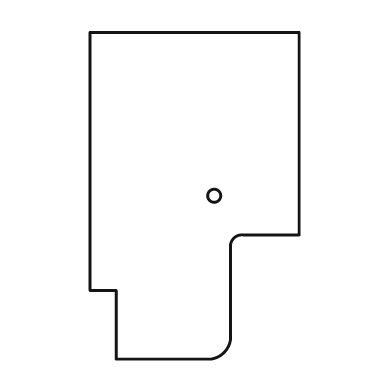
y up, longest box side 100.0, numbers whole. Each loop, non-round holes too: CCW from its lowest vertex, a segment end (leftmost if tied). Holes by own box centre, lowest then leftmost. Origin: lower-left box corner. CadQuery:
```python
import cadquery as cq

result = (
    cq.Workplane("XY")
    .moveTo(8.0, 0.0)
    .lineTo(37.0, 0.0)
    .threePointArc((41.0, 2.0), (43.0, 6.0))
    .lineTo(43.0, 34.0)
    .threePointArc((44.0, 37.0), (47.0, 38.0))
    .lineTo(64.0, 38.0)
    .lineTo(64.0, 100.0)
    .lineTo(0.0, 100.0)
    .lineTo(0.0, 21.0)
    .lineTo(8.0, 21.0)
    .close()
    .moveTo(38.0, 50.0)
    .circle(2.0)
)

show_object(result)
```